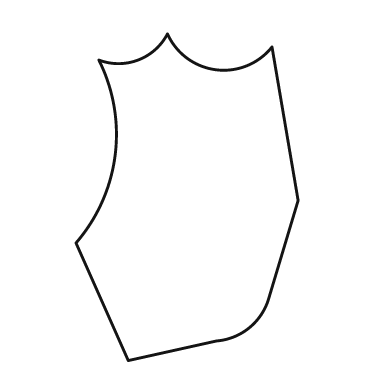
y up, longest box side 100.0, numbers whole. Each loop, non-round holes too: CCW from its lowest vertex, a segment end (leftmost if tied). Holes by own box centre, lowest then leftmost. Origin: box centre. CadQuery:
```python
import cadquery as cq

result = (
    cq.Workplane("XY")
    .moveTo(-18.0, -50.0)
    .lineTo(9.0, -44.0)
    .threePointArc((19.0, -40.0), (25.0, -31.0))
    .lineTo(34.0, -1.0)
    .lineTo(26.0, 46.0)
    .threePointArc((9.0, 39.0), (-6.0, 50.0))
    .threePointArc((-15.0, 42.0), (-27.0, 42.0))
    .threePointArc((-22.0, 13.0), (-34.0, -14.0))
    .close()
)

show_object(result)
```